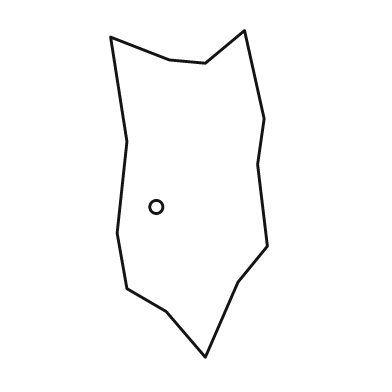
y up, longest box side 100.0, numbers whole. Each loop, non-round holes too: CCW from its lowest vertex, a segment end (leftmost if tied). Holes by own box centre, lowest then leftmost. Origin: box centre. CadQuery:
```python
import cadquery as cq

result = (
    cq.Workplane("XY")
    .moveTo(5.0, -50.0)
    .lineTo(15.0, -27.0)
    .lineTo(24.0, -16.0)
    .lineTo(21.0, 9.0)
    .lineTo(23.0, 23.0)
    .lineTo(17.0, 50.0)
    .lineTo(5.0, 40.0)
    .lineTo(-6.0, 41.0)
    .lineTo(-24.0, 48.0)
    .lineTo(-19.0, 16.0)
    .lineTo(-22.0, -12.0)
    .lineTo(-19.0, -29.0)
    .lineTo(-7.0, -36.0)
    .close()
    .moveTo(-10.0, -4.0)
    .circle(2.0)
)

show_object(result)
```